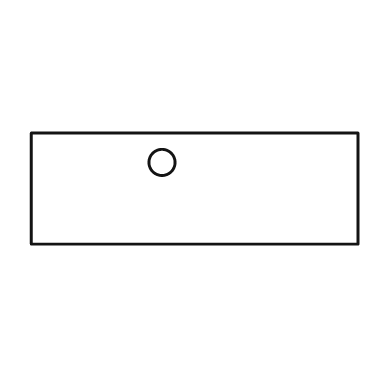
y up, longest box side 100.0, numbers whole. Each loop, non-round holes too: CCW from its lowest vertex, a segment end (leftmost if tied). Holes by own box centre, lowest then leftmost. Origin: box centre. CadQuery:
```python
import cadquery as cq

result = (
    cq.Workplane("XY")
    .moveTo(-50.0, -17.0)
    .lineTo(50.0, -17.0)
    .lineTo(50.0, 17.0)
    .lineTo(-50.0, 17.0)
    .close()
    .moveTo(-10.0, 8.0)
    .circle(4.0)
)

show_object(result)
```